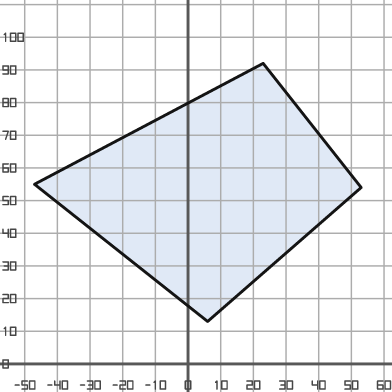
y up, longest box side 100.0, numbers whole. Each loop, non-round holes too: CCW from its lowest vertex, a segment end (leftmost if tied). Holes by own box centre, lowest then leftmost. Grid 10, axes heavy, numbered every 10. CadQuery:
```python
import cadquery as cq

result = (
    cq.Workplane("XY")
    .moveTo(6.0, 13.0)
    .lineTo(53.0, 54.0)
    .lineTo(23.0, 92.0)
    .lineTo(-47.0, 55.0)
    .close()
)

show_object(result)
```